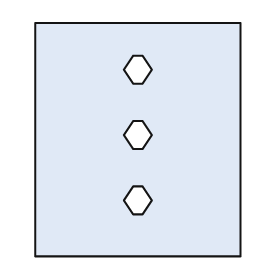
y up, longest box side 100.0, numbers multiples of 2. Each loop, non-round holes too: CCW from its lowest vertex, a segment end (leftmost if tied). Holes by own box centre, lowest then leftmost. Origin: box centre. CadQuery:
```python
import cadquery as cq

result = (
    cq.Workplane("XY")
    .moveTo(-44.0, -50.0)
    .lineTo(44.0, -50.0)
    .lineTo(44.0, 50.0)
    .lineTo(-44.0, 50.0)
    .close()
    .moveTo(-2.0, -32.0)
    .lineTo(2.0, -32.0)
    .lineTo(6.0, -26.0)
    .lineTo(2.0, -20.0)
    .lineTo(-2.0, -20.0)
    .lineTo(-6.0, -26.0)
    .close()
    .moveTo(-2.0, -4.0)
    .lineTo(2.0, -4.0)
    .lineTo(6.0, 2.0)
    .lineTo(2.0, 8.0)
    .lineTo(-2.0, 8.0)
    .lineTo(-6.0, 2.0)
    .close()
    .moveTo(-2.0, 24.0)
    .lineTo(2.0, 24.0)
    .lineTo(6.0, 30.0)
    .lineTo(2.0, 36.0)
    .lineTo(-2.0, 36.0)
    .lineTo(-6.0, 30.0)
    .close()
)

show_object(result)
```